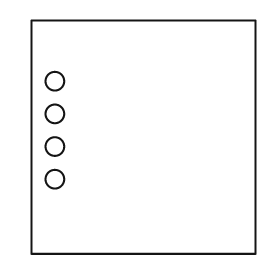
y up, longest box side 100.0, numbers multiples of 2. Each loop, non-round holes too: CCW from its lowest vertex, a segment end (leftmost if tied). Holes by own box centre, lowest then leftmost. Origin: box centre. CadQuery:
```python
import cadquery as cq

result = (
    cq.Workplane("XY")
    .moveTo(-48.0, -50.0)
    .lineTo(48.0, -50.0)
    .lineTo(48.0, 50.0)
    .lineTo(-48.0, 50.0)
    .close()
    .moveTo(-38.0, -18.0)
    .circle(4.0)
    .moveTo(-38.0, -4.0)
    .circle(4.0)
    .moveTo(-38.0, 10.0)
    .circle(4.0)
    .moveTo(-38.0, 24.0)
    .circle(4.0)
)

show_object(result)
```